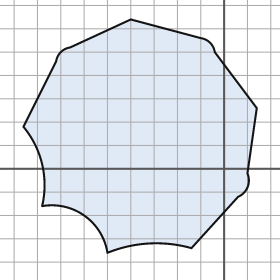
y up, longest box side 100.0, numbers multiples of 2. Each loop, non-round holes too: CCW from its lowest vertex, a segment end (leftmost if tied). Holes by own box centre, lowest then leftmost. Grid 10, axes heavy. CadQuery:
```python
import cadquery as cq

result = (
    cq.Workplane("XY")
    .moveTo(-50.0, -36.0)
    .threePointArc((-32.0, -32.0), (-14.0, -34.0))
    .lineTo(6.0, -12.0)
    .threePointArc((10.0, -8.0), (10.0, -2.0))
    .lineTo(14.0, 26.0)
    .lineTo(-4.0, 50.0)
    .threePointArc((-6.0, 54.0), (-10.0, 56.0))
    .lineTo(-40.0, 64.0)
    .lineTo(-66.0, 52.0)
    .threePointArc((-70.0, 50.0), (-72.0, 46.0))
    .lineTo(-86.0, 18.0)
    .threePointArc((-78.0, 2.0), (-78.0, -16.0))
    .threePointArc((-60.0, -20.0), (-50.0, -36.0))
    .close()
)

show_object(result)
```